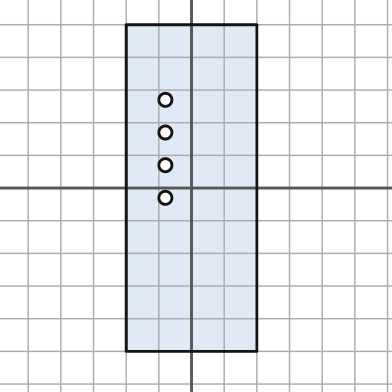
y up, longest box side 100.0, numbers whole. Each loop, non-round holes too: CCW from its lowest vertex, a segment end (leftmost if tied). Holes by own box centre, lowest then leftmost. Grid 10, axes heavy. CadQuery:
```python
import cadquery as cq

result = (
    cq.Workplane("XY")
    .moveTo(-20.0, -50.0)
    .lineTo(20.0, -50.0)
    .lineTo(20.0, 50.0)
    .lineTo(-20.0, 50.0)
    .close()
    .moveTo(-8.0, -3.0)
    .circle(2.0)
    .moveTo(-8.0, 7.0)
    .circle(2.0)
    .moveTo(-8.0, 17.0)
    .circle(2.0)
    .moveTo(-8.0, 27.0)
    .circle(2.0)
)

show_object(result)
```